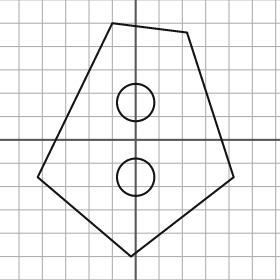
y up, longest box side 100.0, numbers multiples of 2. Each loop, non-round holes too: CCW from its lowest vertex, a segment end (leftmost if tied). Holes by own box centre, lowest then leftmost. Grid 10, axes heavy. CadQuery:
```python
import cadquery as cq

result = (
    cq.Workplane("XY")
    .moveTo(-2.0, -50.0)
    .lineTo(42.0, -16.0)
    .lineTo(22.0, 46.0)
    .lineTo(-10.0, 50.0)
    .lineTo(-42.0, -16.0)
    .close()
    .moveTo(0.0, -16.0)
    .circle(8.0)
    .moveTo(0.0, 16.0)
    .circle(8.0)
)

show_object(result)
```